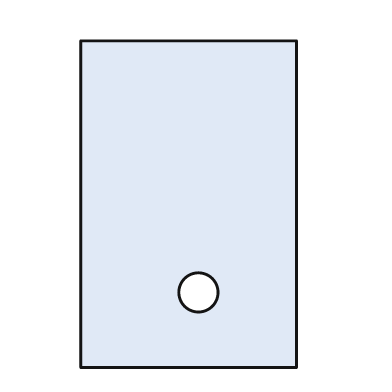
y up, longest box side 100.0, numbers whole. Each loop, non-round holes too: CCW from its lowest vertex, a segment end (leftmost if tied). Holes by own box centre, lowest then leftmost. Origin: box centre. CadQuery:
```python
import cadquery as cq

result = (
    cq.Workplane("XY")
    .moveTo(-33.0, -50.0)
    .lineTo(33.0, -50.0)
    .lineTo(33.0, 50.0)
    .lineTo(-33.0, 50.0)
    .close()
    .moveTo(3.0, -27.0)
    .circle(6.0)
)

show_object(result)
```